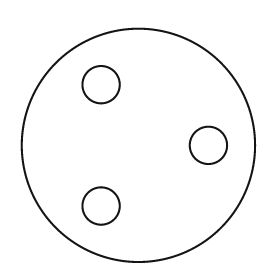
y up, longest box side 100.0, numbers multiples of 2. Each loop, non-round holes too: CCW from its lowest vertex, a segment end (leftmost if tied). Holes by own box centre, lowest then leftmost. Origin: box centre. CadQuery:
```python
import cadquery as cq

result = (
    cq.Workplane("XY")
    .moveTo(0.0, 0.0)
    .circle(50.0)
    .moveTo(-16.0, -26.0)
    .circle(8.0)
    .moveTo(30.0, 0.0)
    .circle(8.0)
    .moveTo(-16.0, 26.0)
    .circle(8.0)
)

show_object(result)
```